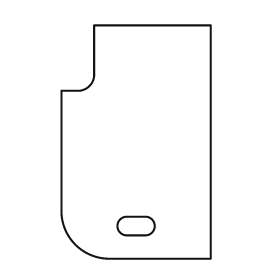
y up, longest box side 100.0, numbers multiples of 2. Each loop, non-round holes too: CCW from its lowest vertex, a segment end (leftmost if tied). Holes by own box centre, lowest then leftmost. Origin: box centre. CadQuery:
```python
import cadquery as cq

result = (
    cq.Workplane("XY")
    .moveTo(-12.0, -50.0)
    .lineTo(32.0, -50.0)
    .lineTo(32.0, 50.0)
    .lineTo(-18.0, 50.0)
    .lineTo(-18.0, 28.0)
    .threePointArc((-20.0, 24.0), (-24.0, 22.0))
    .lineTo(-32.0, 22.0)
    .lineTo(-32.0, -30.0)
    .threePointArc((-26.0, -44.0), (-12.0, -50.0))
    .close()
    .moveTo(-4.0, -40.0)
    .lineTo(4.0, -40.0)
    .threePointArc((8.0, -36.0), (4.0, -32.0))
    .lineTo(-4.0, -32.0)
    .threePointArc((-8.0, -36.0), (-4.0, -40.0))
    .close()
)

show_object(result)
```